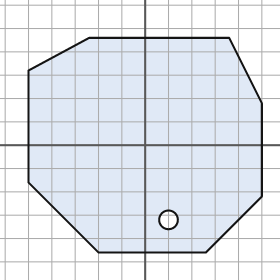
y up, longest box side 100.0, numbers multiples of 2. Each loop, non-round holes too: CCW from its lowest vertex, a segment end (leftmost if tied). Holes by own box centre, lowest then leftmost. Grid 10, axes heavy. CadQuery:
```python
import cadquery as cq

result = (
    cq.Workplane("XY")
    .moveTo(-20.0, -46.0)
    .lineTo(26.0, -46.0)
    .lineTo(50.0, -22.0)
    .lineTo(50.0, 18.0)
    .lineTo(36.0, 46.0)
    .lineTo(-24.0, 46.0)
    .lineTo(-50.0, 32.0)
    .lineTo(-50.0, -16.0)
    .close()
    .moveTo(10.0, -32.0)
    .circle(4.0)
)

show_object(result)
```